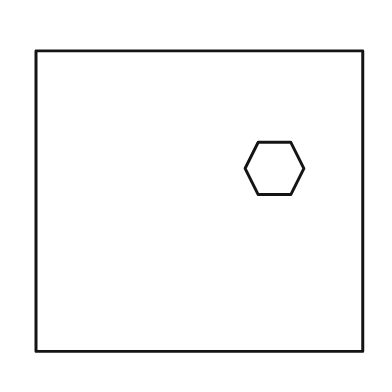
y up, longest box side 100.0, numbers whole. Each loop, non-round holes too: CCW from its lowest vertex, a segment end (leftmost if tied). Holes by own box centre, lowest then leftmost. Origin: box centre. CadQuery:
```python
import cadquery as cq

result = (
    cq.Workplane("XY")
    .moveTo(-50.0, -46.0)
    .lineTo(50.0, -46.0)
    .lineTo(50.0, 46.0)
    .lineTo(-50.0, 46.0)
    .close()
    .moveTo(18.0, 2.0)
    .lineTo(28.0, 2.0)
    .lineTo(32.0, 10.0)
    .lineTo(28.0, 18.0)
    .lineTo(18.0, 18.0)
    .lineTo(14.0, 10.0)
    .close()
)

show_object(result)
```